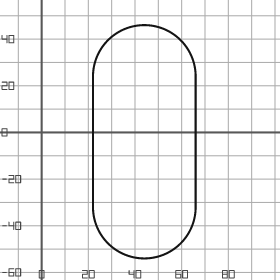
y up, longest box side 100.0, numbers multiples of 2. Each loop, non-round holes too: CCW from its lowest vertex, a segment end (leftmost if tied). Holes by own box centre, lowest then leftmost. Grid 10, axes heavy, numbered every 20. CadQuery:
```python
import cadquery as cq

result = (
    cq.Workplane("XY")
    .moveTo(22.0, -32.0)
    .threePointArc((44.0, -54.0), (66.0, -32.0))
    .lineTo(66.0, 24.0)
    .threePointArc((44.0, 46.0), (22.0, 24.0))
    .close()
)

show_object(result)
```